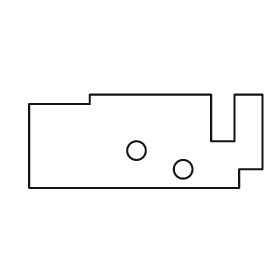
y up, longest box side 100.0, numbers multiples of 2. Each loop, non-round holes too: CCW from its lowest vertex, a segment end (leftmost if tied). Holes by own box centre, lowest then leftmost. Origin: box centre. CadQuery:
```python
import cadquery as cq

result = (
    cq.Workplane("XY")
    .moveTo(-50.0, -20.0)
    .lineTo(40.0, -20.0)
    .lineTo(40.0, -12.0)
    .lineTo(50.0, -12.0)
    .lineTo(50.0, 20.0)
    .lineTo(38.0, 20.0)
    .lineTo(38.0, 0.0)
    .lineTo(28.0, 0.0)
    .lineTo(28.0, 20.0)
    .lineTo(-24.0, 20.0)
    .lineTo(-24.0, 16.0)
    .lineTo(-50.0, 16.0)
    .close()
    .moveTo(16.0, -12.0)
    .circle(4.0)
    .moveTo(-4.0, -4.0)
    .circle(4.0)
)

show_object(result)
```